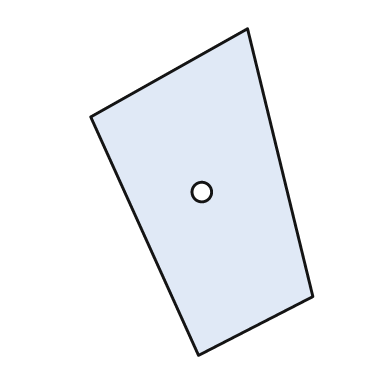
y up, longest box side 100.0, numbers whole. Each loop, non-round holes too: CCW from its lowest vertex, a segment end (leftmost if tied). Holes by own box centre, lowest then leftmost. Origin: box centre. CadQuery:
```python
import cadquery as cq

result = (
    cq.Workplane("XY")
    .moveTo(-1.0, -50.0)
    .lineTo(34.0, -32.0)
    .lineTo(14.0, 50.0)
    .lineTo(-34.0, 23.0)
    .close()
    .moveTo(0.0, 0.0)
    .circle(3.0)
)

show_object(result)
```